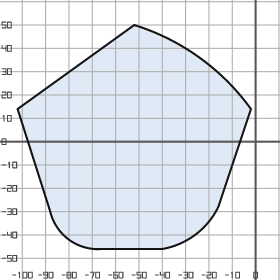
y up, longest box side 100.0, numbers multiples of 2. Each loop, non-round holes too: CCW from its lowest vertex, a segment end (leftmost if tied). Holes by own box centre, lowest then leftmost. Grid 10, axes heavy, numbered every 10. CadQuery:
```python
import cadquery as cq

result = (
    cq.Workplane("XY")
    .moveTo(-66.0, -46.0)
    .lineTo(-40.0, -46.0)
    .threePointArc((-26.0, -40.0), (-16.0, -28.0))
    .lineTo(-2.0, 14.0)
    .threePointArc((-24.0, 36.0), (-52.0, 50.0))
    .lineTo(-102.0, 14.0)
    .lineTo(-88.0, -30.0)
    .threePointArc((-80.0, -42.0), (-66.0, -46.0))
    .close()
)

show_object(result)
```